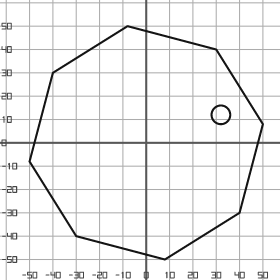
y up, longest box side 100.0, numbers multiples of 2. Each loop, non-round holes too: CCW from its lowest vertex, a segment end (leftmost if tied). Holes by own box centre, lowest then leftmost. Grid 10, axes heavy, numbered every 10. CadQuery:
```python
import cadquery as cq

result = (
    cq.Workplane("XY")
    .moveTo(8.0, -50.0)
    .lineTo(40.0, -30.0)
    .lineTo(50.0, 8.0)
    .lineTo(30.0, 40.0)
    .lineTo(-8.0, 50.0)
    .lineTo(-40.0, 30.0)
    .lineTo(-50.0, -8.0)
    .lineTo(-30.0, -40.0)
    .close()
    .moveTo(32.0, 12.0)
    .circle(4.0)
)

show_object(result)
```